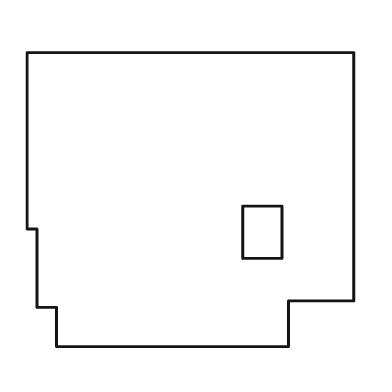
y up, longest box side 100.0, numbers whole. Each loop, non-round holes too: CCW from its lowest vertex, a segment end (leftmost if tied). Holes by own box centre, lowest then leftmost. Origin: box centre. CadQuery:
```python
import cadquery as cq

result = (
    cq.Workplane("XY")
    .moveTo(-41.0, -45.0)
    .lineTo(30.0, -45.0)
    .lineTo(30.0, -31.0)
    .lineTo(50.0, -31.0)
    .lineTo(50.0, 45.0)
    .lineTo(-50.0, 45.0)
    .lineTo(-50.0, -9.0)
    .lineTo(-47.0, -9.0)
    .lineTo(-47.0, -33.0)
    .lineTo(-41.0, -33.0)
    .close()
    .moveTo(16.0, -18.0)
    .lineTo(28.0, -18.0)
    .lineTo(28.0, -2.0)
    .lineTo(16.0, -2.0)
    .close()
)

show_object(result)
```